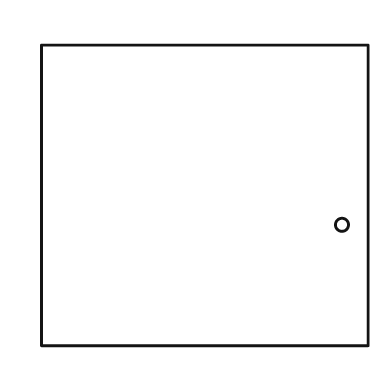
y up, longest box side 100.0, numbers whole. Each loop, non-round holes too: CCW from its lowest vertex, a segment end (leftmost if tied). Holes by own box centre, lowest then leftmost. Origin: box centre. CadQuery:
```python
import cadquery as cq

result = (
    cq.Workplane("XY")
    .moveTo(-50.0, -46.0)
    .lineTo(50.0, -46.0)
    .lineTo(50.0, 46.0)
    .lineTo(-50.0, 46.0)
    .close()
    .moveTo(42.0, -9.0)
    .circle(2.0)
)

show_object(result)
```